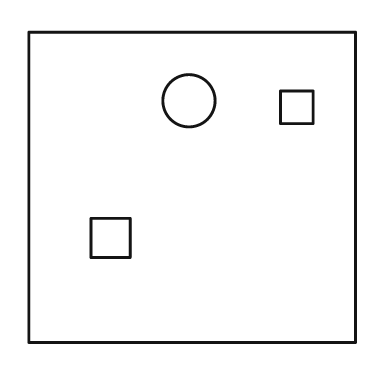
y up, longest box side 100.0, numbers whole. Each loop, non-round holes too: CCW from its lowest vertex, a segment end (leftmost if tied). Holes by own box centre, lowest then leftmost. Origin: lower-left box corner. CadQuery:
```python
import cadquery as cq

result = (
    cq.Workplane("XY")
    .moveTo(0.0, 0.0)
    .lineTo(100.0, 0.0)
    .lineTo(100.0, 95.0)
    .lineTo(0.0, 95.0)
    .close()
    .moveTo(19.0, 26.0)
    .lineTo(31.0, 26.0)
    .lineTo(31.0, 38.0)
    .lineTo(19.0, 38.0)
    .close()
    .moveTo(77.0, 67.0)
    .lineTo(87.0, 67.0)
    .lineTo(87.0, 77.0)
    .lineTo(77.0, 77.0)
    .close()
    .moveTo(49.0, 74.0)
    .circle(8.0)
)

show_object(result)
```